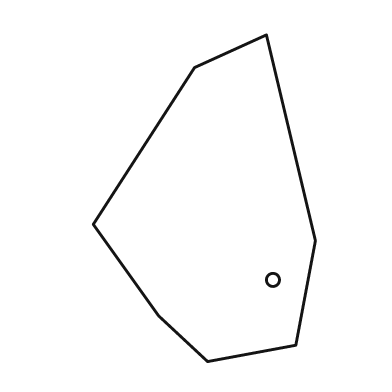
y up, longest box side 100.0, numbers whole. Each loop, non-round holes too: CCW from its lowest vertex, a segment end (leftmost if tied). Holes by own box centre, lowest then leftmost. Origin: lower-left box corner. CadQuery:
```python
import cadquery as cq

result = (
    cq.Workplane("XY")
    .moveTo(35.0, 0.0)
    .lineTo(62.0, 5.0)
    .lineTo(68.0, 37.0)
    .lineTo(53.0, 100.0)
    .lineTo(31.0, 90.0)
    .lineTo(0.0, 42.0)
    .lineTo(20.0, 14.0)
    .close()
    .moveTo(55.0, 25.0)
    .circle(2.0)
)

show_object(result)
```